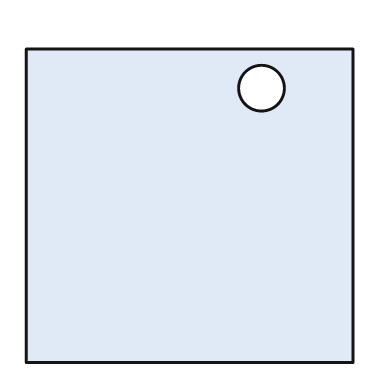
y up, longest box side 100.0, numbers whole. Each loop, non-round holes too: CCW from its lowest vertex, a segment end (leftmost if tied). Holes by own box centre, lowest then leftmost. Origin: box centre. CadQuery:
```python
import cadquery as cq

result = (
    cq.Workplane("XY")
    .moveTo(-50.0, -48.0)
    .lineTo(50.0, -48.0)
    .lineTo(50.0, 48.0)
    .lineTo(-50.0, 48.0)
    .close()
    .moveTo(22.0, 36.0)
    .circle(7.0)
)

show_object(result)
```